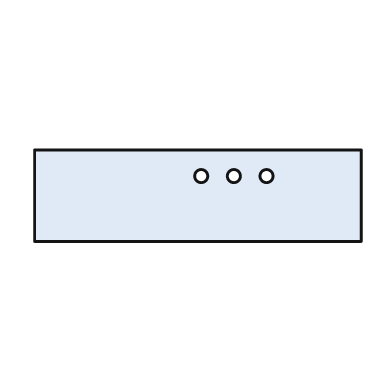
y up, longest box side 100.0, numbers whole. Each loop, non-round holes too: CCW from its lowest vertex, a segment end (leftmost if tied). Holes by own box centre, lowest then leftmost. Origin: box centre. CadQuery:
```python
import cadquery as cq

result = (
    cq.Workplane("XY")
    .moveTo(-50.0, -14.0)
    .lineTo(50.0, -14.0)
    .lineTo(50.0, 14.0)
    .lineTo(-50.0, 14.0)
    .close()
    .moveTo(1.0, 6.0)
    .circle(2.0)
    .moveTo(11.0, 6.0)
    .circle(2.0)
    .moveTo(21.0, 6.0)
    .circle(2.0)
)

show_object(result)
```